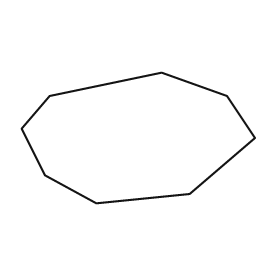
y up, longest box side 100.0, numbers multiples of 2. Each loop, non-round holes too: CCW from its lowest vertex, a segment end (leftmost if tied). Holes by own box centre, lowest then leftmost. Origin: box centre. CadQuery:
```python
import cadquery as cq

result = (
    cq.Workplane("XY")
    .moveTo(-18.0, -28.0)
    .lineTo(22.0, -24.0)
    .lineTo(50.0, 0.0)
    .lineTo(38.0, 18.0)
    .lineTo(10.0, 28.0)
    .lineTo(-38.0, 18.0)
    .lineTo(-50.0, 4.0)
    .lineTo(-40.0, -16.0)
    .close()
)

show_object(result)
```